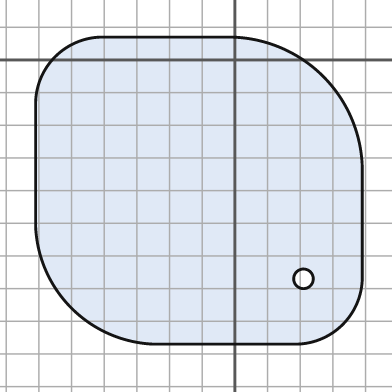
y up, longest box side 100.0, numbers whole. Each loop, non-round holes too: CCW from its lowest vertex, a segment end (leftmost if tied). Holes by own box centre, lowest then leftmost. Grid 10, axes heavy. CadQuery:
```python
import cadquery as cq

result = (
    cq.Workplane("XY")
    .moveTo(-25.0, -87.0)
    .lineTo(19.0, -87.0)
    .threePointArc((33.0, -81.0), (39.0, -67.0))
    .lineTo(39.0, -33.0)
    .threePointArc((27.0, -5.0), (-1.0, 7.0))
    .lineTo(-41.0, 7.0)
    .threePointArc((-55.0, 1.0), (-61.0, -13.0))
    .lineTo(-61.0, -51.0)
    .threePointArc((-50.0, -76.0), (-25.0, -87.0))
    .close()
    .moveTo(21.0, -67.0)
    .circle(3.0)
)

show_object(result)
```